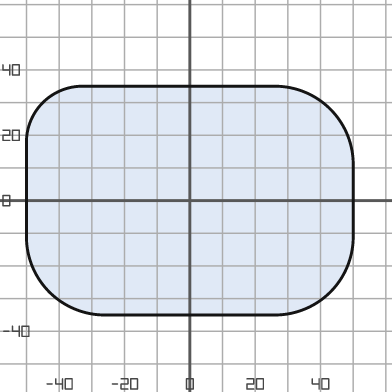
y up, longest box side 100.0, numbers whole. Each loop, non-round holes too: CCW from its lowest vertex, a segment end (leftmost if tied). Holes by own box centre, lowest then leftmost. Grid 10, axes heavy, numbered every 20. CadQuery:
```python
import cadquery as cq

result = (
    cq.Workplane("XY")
    .moveTo(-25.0, -35.0)
    .lineTo(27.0, -35.0)
    .threePointArc((43.0, -28.0), (50.0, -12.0))
    .lineTo(50.0, 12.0)
    .threePointArc((43.0, 28.0), (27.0, 35.0))
    .lineTo(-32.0, 35.0)
    .threePointArc((-45.0, 30.0), (-50.0, 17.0))
    .lineTo(-50.0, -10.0)
    .threePointArc((-43.0, -28.0), (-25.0, -35.0))
    .close()
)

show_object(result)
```